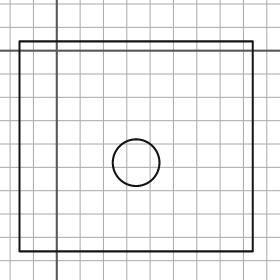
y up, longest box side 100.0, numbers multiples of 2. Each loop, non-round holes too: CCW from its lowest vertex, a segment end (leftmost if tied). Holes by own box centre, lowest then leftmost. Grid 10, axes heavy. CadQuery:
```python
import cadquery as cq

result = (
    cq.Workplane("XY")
    .moveTo(-16.0, -86.0)
    .lineTo(84.0, -86.0)
    .lineTo(84.0, 4.0)
    .lineTo(-16.0, 4.0)
    .close()
    .moveTo(34.0, -48.0)
    .circle(10.0)
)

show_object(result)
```